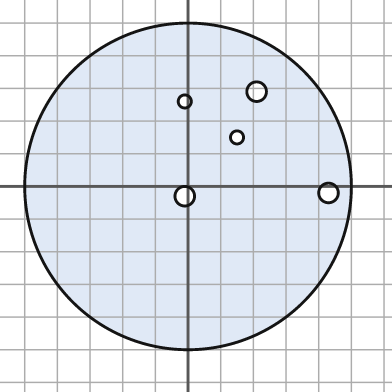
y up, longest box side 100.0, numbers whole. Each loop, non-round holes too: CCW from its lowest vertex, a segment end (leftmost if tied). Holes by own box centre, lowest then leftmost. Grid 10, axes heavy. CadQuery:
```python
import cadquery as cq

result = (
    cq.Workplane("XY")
    .moveTo(0.0, 0.0)
    .circle(50.0)
    .moveTo(-1.0, -3.0)
    .circle(3.0)
    .moveTo(43.0, -2.0)
    .circle(3.0)
    .moveTo(15.0, 15.0)
    .circle(2.0)
    .moveTo(-1.0, 26.0)
    .circle(2.0)
    .moveTo(21.0, 29.0)
    .circle(3.0)
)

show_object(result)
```